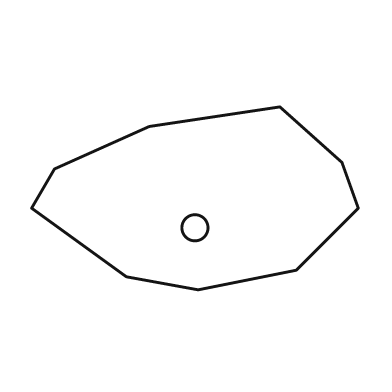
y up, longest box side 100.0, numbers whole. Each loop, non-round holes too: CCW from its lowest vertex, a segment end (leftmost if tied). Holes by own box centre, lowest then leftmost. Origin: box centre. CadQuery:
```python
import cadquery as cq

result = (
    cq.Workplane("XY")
    .moveTo(1.0, -28.0)
    .lineTo(31.0, -22.0)
    .lineTo(50.0, -3.0)
    .lineTo(45.0, 11.0)
    .lineTo(26.0, 28.0)
    .lineTo(-14.0, 22.0)
    .lineTo(-43.0, 9.0)
    .lineTo(-50.0, -3.0)
    .lineTo(-21.0, -24.0)
    .close()
    .moveTo(0.0, -9.0)
    .circle(4.0)
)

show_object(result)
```